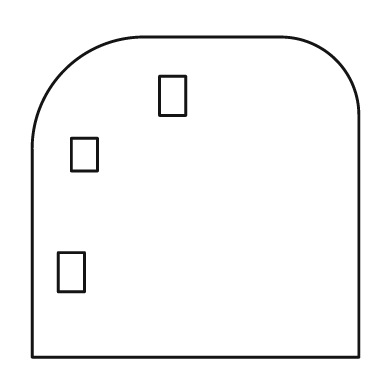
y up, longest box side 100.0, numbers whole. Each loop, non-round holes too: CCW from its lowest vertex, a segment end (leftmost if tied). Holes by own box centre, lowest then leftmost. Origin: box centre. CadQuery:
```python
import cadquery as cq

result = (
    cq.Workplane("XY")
    .moveTo(-50.0, -49.0)
    .lineTo(50.0, -49.0)
    .lineTo(50.0, 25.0)
    .threePointArc((43.0, 42.0), (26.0, 49.0))
    .lineTo(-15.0, 49.0)
    .threePointArc((-40.0, 39.0), (-50.0, 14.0))
    .close()
    .moveTo(-42.0, -29.0)
    .lineTo(-34.0, -29.0)
    .lineTo(-34.0, -17.0)
    .lineTo(-42.0, -17.0)
    .close()
    .moveTo(-38.0, 8.0)
    .lineTo(-30.0, 8.0)
    .lineTo(-30.0, 18.0)
    .lineTo(-38.0, 18.0)
    .close()
    .moveTo(-11.0, 25.0)
    .lineTo(-3.0, 25.0)
    .lineTo(-3.0, 37.0)
    .lineTo(-11.0, 37.0)
    .close()
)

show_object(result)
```